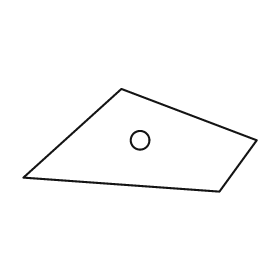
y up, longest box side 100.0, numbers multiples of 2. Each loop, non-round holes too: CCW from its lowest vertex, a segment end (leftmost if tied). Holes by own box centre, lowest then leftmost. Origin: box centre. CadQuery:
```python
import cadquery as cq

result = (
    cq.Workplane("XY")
    .moveTo(34.0, -22.0)
    .lineTo(50.0, 0.0)
    .lineTo(-8.0, 22.0)
    .lineTo(-50.0, -16.0)
    .close()
    .moveTo(0.0, 0.0)
    .circle(4.0)
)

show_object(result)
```